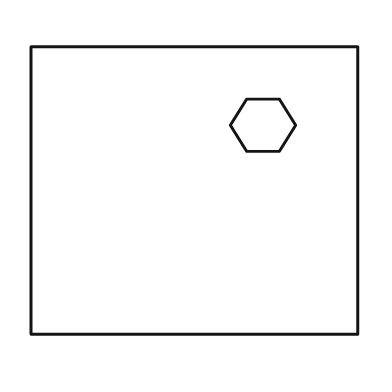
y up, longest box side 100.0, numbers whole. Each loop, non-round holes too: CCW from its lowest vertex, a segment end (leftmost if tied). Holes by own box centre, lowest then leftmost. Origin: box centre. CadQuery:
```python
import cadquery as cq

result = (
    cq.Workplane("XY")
    .moveTo(-50.0, -44.0)
    .lineTo(50.0, -44.0)
    .lineTo(50.0, 44.0)
    .lineTo(-50.0, 44.0)
    .close()
    .moveTo(16.0, 12.0)
    .lineTo(26.0, 12.0)
    .lineTo(31.0, 20.0)
    .lineTo(26.0, 28.0)
    .lineTo(16.0, 28.0)
    .lineTo(11.0, 20.0)
    .close()
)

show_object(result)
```